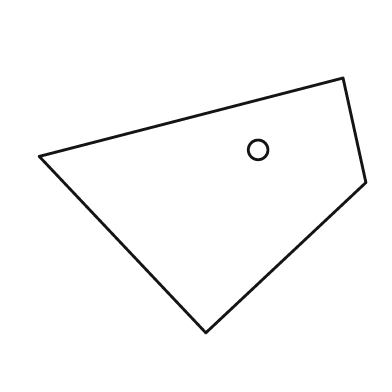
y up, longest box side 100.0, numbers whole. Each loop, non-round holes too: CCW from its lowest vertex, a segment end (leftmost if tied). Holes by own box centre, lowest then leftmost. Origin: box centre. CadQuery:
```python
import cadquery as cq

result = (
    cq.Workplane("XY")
    .moveTo(1.0, -39.0)
    .lineTo(50.0, 7.0)
    .lineTo(43.0, 39.0)
    .lineTo(-50.0, 15.0)
    .close()
    .moveTo(17.0, 17.0)
    .circle(3.0)
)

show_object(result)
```